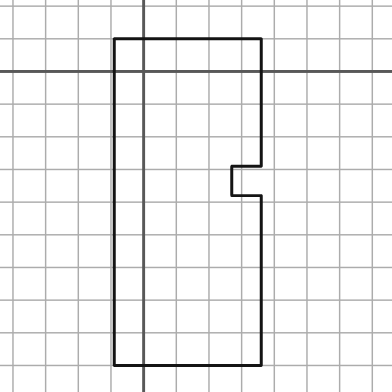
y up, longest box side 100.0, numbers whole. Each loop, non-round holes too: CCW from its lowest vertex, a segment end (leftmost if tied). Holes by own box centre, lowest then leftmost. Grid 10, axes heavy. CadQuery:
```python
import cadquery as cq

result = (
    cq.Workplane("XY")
    .moveTo(-9.0, -90.0)
    .lineTo(36.0, -90.0)
    .lineTo(36.0, -38.0)
    .lineTo(27.0, -38.0)
    .lineTo(27.0, -29.0)
    .lineTo(36.0, -29.0)
    .lineTo(36.0, 10.0)
    .lineTo(-9.0, 10.0)
    .close()
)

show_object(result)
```